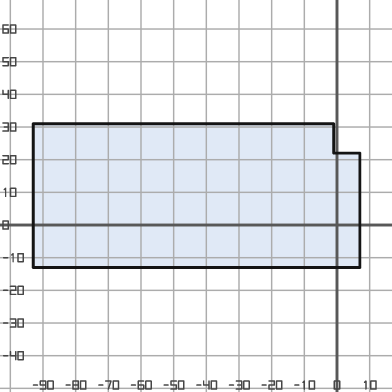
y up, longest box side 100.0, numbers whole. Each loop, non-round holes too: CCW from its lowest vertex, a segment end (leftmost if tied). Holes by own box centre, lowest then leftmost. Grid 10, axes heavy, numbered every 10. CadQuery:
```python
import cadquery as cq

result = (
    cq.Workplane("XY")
    .moveTo(-93.0, -13.0)
    .lineTo(7.0, -13.0)
    .lineTo(7.0, 22.0)
    .lineTo(-1.0, 22.0)
    .lineTo(-1.0, 31.0)
    .lineTo(-93.0, 31.0)
    .close()
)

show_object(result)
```